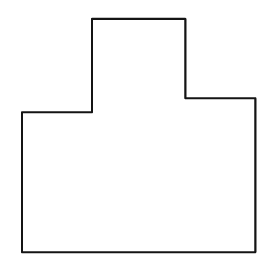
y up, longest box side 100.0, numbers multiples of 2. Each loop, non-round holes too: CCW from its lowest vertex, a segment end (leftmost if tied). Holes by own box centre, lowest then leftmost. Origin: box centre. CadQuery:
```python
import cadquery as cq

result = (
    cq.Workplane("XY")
    .moveTo(-50.0, -50.0)
    .lineTo(50.0, -50.0)
    .lineTo(50.0, 16.0)
    .lineTo(20.0, 16.0)
    .lineTo(20.0, 50.0)
    .lineTo(-20.0, 50.0)
    .lineTo(-20.0, 10.0)
    .lineTo(-50.0, 10.0)
    .close()
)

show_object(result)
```